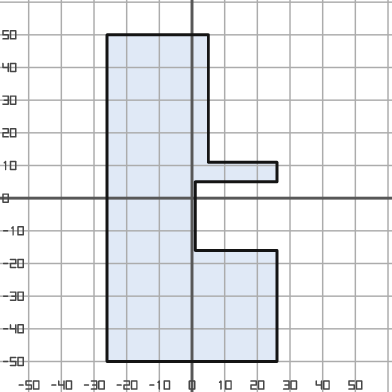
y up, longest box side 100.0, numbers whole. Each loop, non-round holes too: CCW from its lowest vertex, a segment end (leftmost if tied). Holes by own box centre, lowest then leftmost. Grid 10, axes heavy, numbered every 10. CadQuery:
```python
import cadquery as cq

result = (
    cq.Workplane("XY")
    .moveTo(-26.0, -50.0)
    .lineTo(26.0, -50.0)
    .lineTo(26.0, -16.0)
    .lineTo(1.0, -16.0)
    .lineTo(1.0, 5.0)
    .lineTo(26.0, 5.0)
    .lineTo(26.0, 11.0)
    .lineTo(5.0, 11.0)
    .lineTo(5.0, 50.0)
    .lineTo(-26.0, 50.0)
    .close()
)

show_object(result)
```